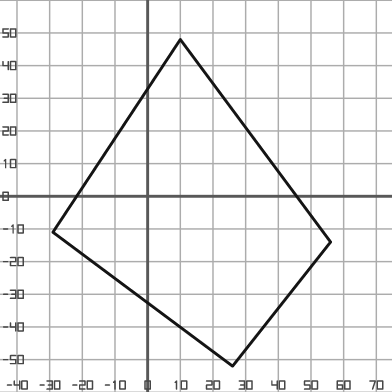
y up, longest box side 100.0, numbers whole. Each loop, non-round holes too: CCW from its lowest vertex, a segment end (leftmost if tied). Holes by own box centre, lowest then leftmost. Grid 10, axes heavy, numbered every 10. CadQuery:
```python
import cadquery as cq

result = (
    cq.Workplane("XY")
    .moveTo(26.0, -52.0)
    .lineTo(56.0, -14.0)
    .lineTo(10.0, 48.0)
    .lineTo(-29.0, -11.0)
    .close()
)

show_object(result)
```